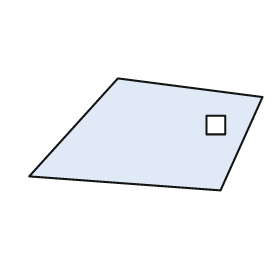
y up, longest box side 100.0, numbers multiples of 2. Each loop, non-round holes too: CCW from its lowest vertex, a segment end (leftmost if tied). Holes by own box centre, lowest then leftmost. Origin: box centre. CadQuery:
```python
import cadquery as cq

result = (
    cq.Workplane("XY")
    .moveTo(32.0, -24.0)
    .lineTo(50.0, 16.0)
    .lineTo(-12.0, 24.0)
    .lineTo(-50.0, -18.0)
    .close()
    .moveTo(26.0, 0.0)
    .lineTo(34.0, 0.0)
    .lineTo(34.0, 8.0)
    .lineTo(26.0, 8.0)
    .close()
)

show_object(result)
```